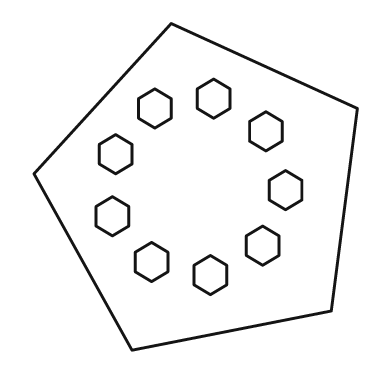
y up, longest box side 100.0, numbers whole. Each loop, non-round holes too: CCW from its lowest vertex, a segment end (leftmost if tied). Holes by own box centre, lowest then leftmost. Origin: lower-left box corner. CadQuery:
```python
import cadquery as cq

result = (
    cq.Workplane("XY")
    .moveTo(30.0, 0.0)
    .lineTo(91.0, 12.0)
    .lineTo(99.0, 74.0)
    .lineTo(42.0, 100.0)
    .lineTo(0.0, 54.0)
    .close()
    .moveTo(54.0, 17.0)
    .lineTo(59.0, 20.0)
    .lineTo(59.0, 26.0)
    .lineTo(54.0, 29.0)
    .lineTo(49.0, 26.0)
    .lineTo(49.0, 20.0)
    .close()
    .moveTo(36.0, 21.0)
    .lineTo(41.0, 24.0)
    .lineTo(41.0, 30.0)
    .lineTo(36.0, 33.0)
    .lineTo(31.0, 30.0)
    .lineTo(31.0, 24.0)
    .close()
    .moveTo(70.0, 26.0)
    .lineTo(75.0, 29.0)
    .lineTo(75.0, 35.0)
    .lineTo(70.0, 38.0)
    .lineTo(65.0, 35.0)
    .lineTo(65.0, 29.0)
    .close()
    .moveTo(24.0, 35.0)
    .lineTo(29.0, 38.0)
    .lineTo(29.0, 44.0)
    .lineTo(24.0, 47.0)
    .lineTo(19.0, 44.0)
    .lineTo(19.0, 38.0)
    .close()
    .moveTo(77.0, 43.0)
    .lineTo(82.0, 46.0)
    .lineTo(82.0, 52.0)
    .lineTo(77.0, 55.0)
    .lineTo(72.0, 52.0)
    .lineTo(72.0, 46.0)
    .close()
    .moveTo(25.0, 54.0)
    .lineTo(30.0, 57.0)
    .lineTo(30.0, 63.0)
    .lineTo(25.0, 66.0)
    .lineTo(20.0, 63.0)
    .lineTo(20.0, 57.0)
    .close()
    .moveTo(71.0, 61.0)
    .lineTo(76.0, 64.0)
    .lineTo(76.0, 70.0)
    .lineTo(71.0, 73.0)
    .lineTo(66.0, 70.0)
    .lineTo(66.0, 64.0)
    .close()
    .moveTo(37.0, 68.0)
    .lineTo(42.0, 71.0)
    .lineTo(42.0, 77.0)
    .lineTo(37.0, 80.0)
    .lineTo(32.0, 77.0)
    .lineTo(32.0, 71.0)
    .close()
    .moveTo(55.0, 71.0)
    .lineTo(60.0, 74.0)
    .lineTo(60.0, 80.0)
    .lineTo(55.0, 83.0)
    .lineTo(50.0, 80.0)
    .lineTo(50.0, 74.0)
    .close()
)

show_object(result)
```